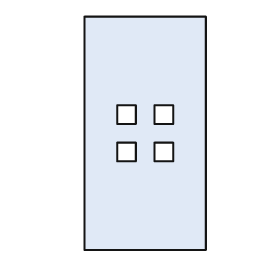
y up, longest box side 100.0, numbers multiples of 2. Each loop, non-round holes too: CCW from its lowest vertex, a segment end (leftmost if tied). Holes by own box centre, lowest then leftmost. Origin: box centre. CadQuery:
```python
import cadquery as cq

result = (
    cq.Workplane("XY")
    .moveTo(-26.0, -50.0)
    .lineTo(26.0, -50.0)
    .lineTo(26.0, 50.0)
    .lineTo(-26.0, 50.0)
    .close()
    .moveTo(-12.0, -12.0)
    .lineTo(-4.0, -12.0)
    .lineTo(-4.0, -4.0)
    .lineTo(-12.0, -4.0)
    .close()
    .moveTo(4.0, -12.0)
    .lineTo(12.0, -12.0)
    .lineTo(12.0, -4.0)
    .lineTo(4.0, -4.0)
    .close()
    .moveTo(-12.0, 4.0)
    .lineTo(-4.0, 4.0)
    .lineTo(-4.0, 12.0)
    .lineTo(-12.0, 12.0)
    .close()
    .moveTo(4.0, 4.0)
    .lineTo(12.0, 4.0)
    .lineTo(12.0, 12.0)
    .lineTo(4.0, 12.0)
    .close()
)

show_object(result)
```